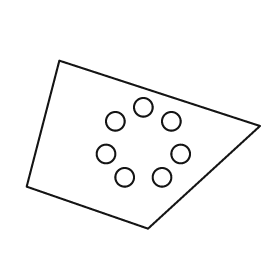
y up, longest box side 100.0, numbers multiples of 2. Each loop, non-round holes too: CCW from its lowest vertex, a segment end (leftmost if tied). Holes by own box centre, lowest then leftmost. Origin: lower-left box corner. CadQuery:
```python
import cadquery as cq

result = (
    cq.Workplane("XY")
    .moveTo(52.0, 0.0)
    .lineTo(100.0, 44.0)
    .lineTo(14.0, 72.0)
    .lineTo(0.0, 18.0)
    .close()
    .moveTo(42.0, 22.0)
    .circle(4.0)
    .moveTo(58.0, 22.0)
    .circle(4.0)
    .moveTo(34.0, 32.0)
    .circle(4.0)
    .moveTo(66.0, 32.0)
    .circle(4.0)
    .moveTo(38.0, 46.0)
    .circle(4.0)
    .moveTo(62.0, 46.0)
    .circle(4.0)
    .moveTo(50.0, 52.0)
    .circle(4.0)
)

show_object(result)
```